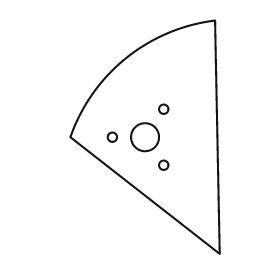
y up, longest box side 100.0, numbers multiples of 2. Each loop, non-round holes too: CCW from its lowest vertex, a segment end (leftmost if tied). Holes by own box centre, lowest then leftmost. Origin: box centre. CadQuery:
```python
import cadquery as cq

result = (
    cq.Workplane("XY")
    .moveTo(32.0, -50.0)
    .lineTo(30.0, 50.0)
    .threePointArc((-8.0, 34.0), (-32.0, 0.0))
    .close()
    .moveTo(8.0, -12.0)
    .circle(2.0)
    .moveTo(-14.0, 0.0)
    .circle(2.0)
    .moveTo(0.0, 0.0)
    .circle(6.0)
    .moveTo(8.0, 12.0)
    .circle(2.0)
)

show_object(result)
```